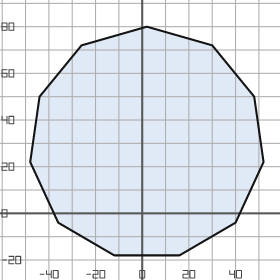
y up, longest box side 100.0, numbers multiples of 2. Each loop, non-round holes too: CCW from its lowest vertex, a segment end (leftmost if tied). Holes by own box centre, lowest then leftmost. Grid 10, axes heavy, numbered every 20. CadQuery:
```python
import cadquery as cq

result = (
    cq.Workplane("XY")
    .moveTo(-12.0, -18.0)
    .lineTo(16.0, -18.0)
    .lineTo(40.0, -4.0)
    .lineTo(52.0, 22.0)
    .lineTo(48.0, 50.0)
    .lineTo(30.0, 72.0)
    .lineTo(2.0, 80.0)
    .lineTo(-26.0, 72.0)
    .lineTo(-44.0, 50.0)
    .lineTo(-48.0, 22.0)
    .lineTo(-36.0, -4.0)
    .close()
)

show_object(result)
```